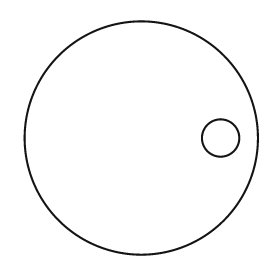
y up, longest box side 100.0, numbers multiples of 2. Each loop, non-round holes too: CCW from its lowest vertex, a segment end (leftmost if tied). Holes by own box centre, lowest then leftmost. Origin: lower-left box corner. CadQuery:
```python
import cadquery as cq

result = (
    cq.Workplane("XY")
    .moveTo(50.0, 50.0)
    .circle(50.0)
    .moveTo(84.0, 50.0)
    .circle(8.0)
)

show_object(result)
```